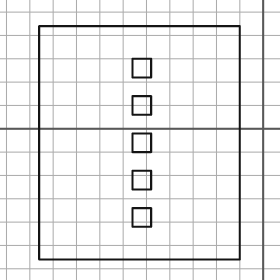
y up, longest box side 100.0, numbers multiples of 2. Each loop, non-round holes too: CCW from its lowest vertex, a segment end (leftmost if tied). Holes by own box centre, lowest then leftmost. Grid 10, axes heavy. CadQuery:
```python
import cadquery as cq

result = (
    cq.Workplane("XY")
    .moveTo(-96.0, -56.0)
    .lineTo(-10.0, -56.0)
    .lineTo(-10.0, 44.0)
    .lineTo(-96.0, 44.0)
    .close()
    .moveTo(-56.0, -42.0)
    .lineTo(-48.0, -42.0)
    .lineTo(-48.0, -34.0)
    .lineTo(-56.0, -34.0)
    .close()
    .moveTo(-56.0, -26.0)
    .lineTo(-48.0, -26.0)
    .lineTo(-48.0, -18.0)
    .lineTo(-56.0, -18.0)
    .close()
    .moveTo(-56.0, -10.0)
    .lineTo(-48.0, -10.0)
    .lineTo(-48.0, -2.0)
    .lineTo(-56.0, -2.0)
    .close()
    .moveTo(-56.0, 6.0)
    .lineTo(-48.0, 6.0)
    .lineTo(-48.0, 14.0)
    .lineTo(-56.0, 14.0)
    .close()
    .moveTo(-56.0, 22.0)
    .lineTo(-48.0, 22.0)
    .lineTo(-48.0, 30.0)
    .lineTo(-56.0, 30.0)
    .close()
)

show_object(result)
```